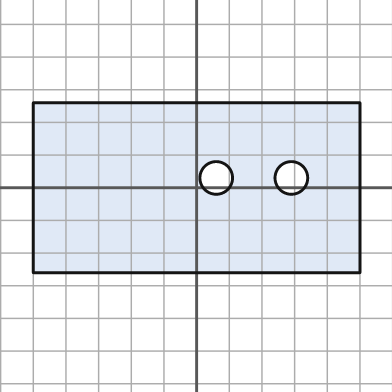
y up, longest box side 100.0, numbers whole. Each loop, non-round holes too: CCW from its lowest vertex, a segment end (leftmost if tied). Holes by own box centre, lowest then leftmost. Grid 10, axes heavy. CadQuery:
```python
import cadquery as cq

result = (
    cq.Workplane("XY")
    .moveTo(-50.0, -26.0)
    .lineTo(50.0, -26.0)
    .lineTo(50.0, 26.0)
    .lineTo(-50.0, 26.0)
    .close()
    .moveTo(6.0, 3.0)
    .circle(5.0)
    .moveTo(29.0, 3.0)
    .circle(5.0)
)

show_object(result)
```